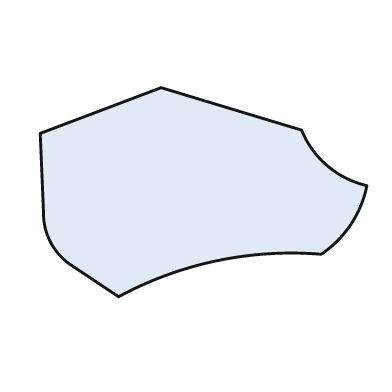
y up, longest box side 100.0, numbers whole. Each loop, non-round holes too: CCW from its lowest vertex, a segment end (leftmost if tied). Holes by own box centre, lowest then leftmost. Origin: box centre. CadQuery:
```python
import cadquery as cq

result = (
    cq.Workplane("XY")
    .moveTo(-26.0, -32.0)
    .threePointArc((4.0, -21.0), (36.0, -19.0))
    .threePointArc((45.0, -10.0), (50.0, 2.0))
    .threePointArc((38.0, 8.0), (30.0, 19.0))
    .lineTo(-13.0, 32.0)
    .lineTo(-50.0, 18.0)
    .lineTo(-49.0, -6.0)
    .threePointArc((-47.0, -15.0), (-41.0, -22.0))
    .close()
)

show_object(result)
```